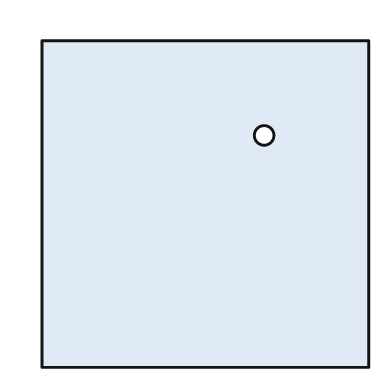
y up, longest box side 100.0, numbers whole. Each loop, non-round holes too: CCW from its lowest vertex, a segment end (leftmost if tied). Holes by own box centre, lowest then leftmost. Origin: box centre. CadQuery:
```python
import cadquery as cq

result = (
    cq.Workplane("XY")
    .moveTo(-50.0, -50.0)
    .lineTo(50.0, -50.0)
    .lineTo(50.0, 50.0)
    .lineTo(-50.0, 50.0)
    .close()
    .moveTo(18.0, 21.0)
    .circle(3.0)
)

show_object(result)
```